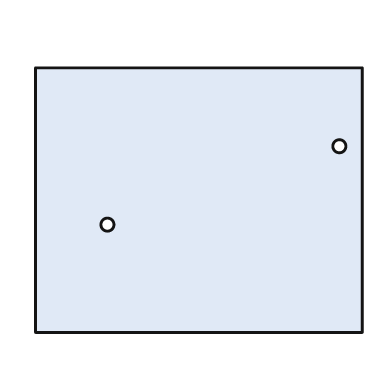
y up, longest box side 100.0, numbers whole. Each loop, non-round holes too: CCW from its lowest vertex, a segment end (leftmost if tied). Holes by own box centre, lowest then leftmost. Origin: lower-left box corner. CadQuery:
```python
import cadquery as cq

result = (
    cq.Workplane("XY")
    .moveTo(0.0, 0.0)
    .lineTo(100.0, 0.0)
    .lineTo(100.0, 81.0)
    .lineTo(0.0, 81.0)
    .close()
    .moveTo(22.0, 33.0)
    .circle(2.0)
    .moveTo(93.0, 57.0)
    .circle(2.0)
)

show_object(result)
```